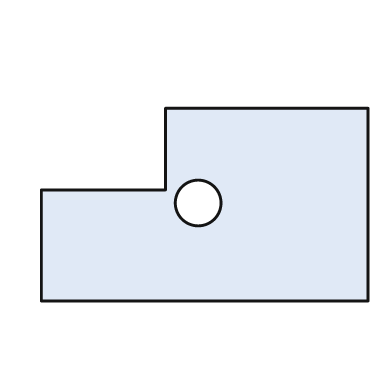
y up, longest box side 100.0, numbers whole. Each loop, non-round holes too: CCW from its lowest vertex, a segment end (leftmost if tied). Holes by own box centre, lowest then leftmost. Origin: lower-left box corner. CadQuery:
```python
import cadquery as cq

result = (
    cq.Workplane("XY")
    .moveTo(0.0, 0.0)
    .lineTo(100.0, 0.0)
    .lineTo(100.0, 59.0)
    .lineTo(38.0, 59.0)
    .lineTo(38.0, 34.0)
    .lineTo(0.0, 34.0)
    .close()
    .moveTo(48.0, 30.0)
    .circle(7.0)
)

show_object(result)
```